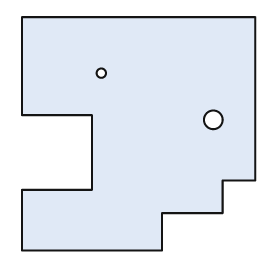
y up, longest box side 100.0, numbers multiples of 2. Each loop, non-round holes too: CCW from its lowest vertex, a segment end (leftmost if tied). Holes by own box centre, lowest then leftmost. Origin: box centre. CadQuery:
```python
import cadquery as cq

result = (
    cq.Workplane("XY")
    .moveTo(-50.0, -50.0)
    .lineTo(10.0, -50.0)
    .lineTo(10.0, -34.0)
    .lineTo(36.0, -34.0)
    .lineTo(36.0, -20.0)
    .lineTo(50.0, -20.0)
    .lineTo(50.0, 50.0)
    .lineTo(-50.0, 50.0)
    .lineTo(-50.0, 8.0)
    .lineTo(-20.0, 8.0)
    .lineTo(-20.0, -24.0)
    .lineTo(-50.0, -24.0)
    .close()
    .moveTo(32.0, 6.0)
    .circle(4.0)
    .moveTo(-16.0, 26.0)
    .circle(2.0)
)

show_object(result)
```